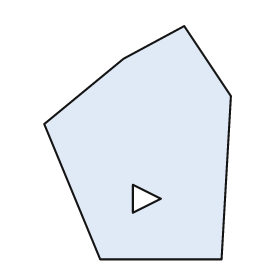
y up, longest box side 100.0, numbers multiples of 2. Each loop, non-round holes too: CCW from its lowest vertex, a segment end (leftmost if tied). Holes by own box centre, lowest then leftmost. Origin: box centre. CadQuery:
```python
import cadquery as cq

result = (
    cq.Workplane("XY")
    .moveTo(-16.0, -50.0)
    .lineTo(36.0, -50.0)
    .lineTo(40.0, 20.0)
    .lineTo(20.0, 50.0)
    .lineTo(-6.0, 36.0)
    .lineTo(-40.0, 8.0)
    .close()
    .moveTo(-2.0, -30.0)
    .lineTo(10.0, -24.0)
    .lineTo(-2.0, -18.0)
    .close()
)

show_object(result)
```